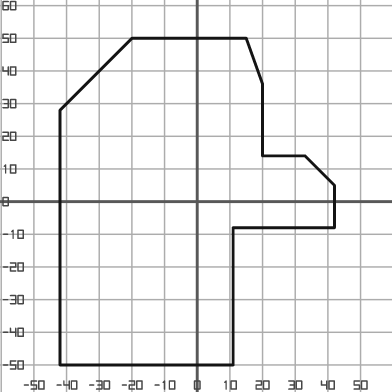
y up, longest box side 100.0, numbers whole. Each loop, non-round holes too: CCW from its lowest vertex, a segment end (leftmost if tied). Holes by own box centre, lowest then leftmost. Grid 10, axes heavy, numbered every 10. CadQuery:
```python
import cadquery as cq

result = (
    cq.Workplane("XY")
    .moveTo(-42.0, -50.0)
    .lineTo(11.0, -50.0)
    .lineTo(11.0, -8.0)
    .lineTo(42.0, -8.0)
    .lineTo(42.0, 5.0)
    .lineTo(33.0, 14.0)
    .lineTo(20.0, 14.0)
    .lineTo(20.0, 36.0)
    .lineTo(15.0, 50.0)
    .lineTo(-20.0, 50.0)
    .lineTo(-42.0, 28.0)
    .close()
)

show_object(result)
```